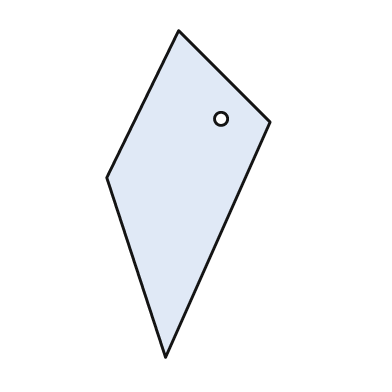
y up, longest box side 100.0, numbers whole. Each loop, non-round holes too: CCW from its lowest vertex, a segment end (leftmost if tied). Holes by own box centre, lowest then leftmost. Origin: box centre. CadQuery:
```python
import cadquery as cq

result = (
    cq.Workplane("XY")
    .moveTo(-7.0, -50.0)
    .lineTo(25.0, 22.0)
    .lineTo(-3.0, 50.0)
    .lineTo(-25.0, 5.0)
    .close()
    .moveTo(10.0, 23.0)
    .circle(2.0)
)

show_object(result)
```